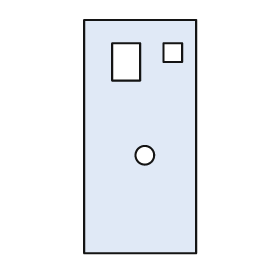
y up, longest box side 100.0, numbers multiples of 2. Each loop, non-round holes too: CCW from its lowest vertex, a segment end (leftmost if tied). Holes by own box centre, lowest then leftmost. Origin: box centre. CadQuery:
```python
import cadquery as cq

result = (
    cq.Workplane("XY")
    .moveTo(-24.0, -50.0)
    .lineTo(24.0, -50.0)
    .lineTo(24.0, 50.0)
    .lineTo(-24.0, 50.0)
    .close()
    .moveTo(2.0, -8.0)
    .circle(4.0)
    .moveTo(-12.0, 24.0)
    .lineTo(0.0, 24.0)
    .lineTo(0.0, 40.0)
    .lineTo(-12.0, 40.0)
    .close()
    .moveTo(10.0, 32.0)
    .lineTo(18.0, 32.0)
    .lineTo(18.0, 40.0)
    .lineTo(10.0, 40.0)
    .close()
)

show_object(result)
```